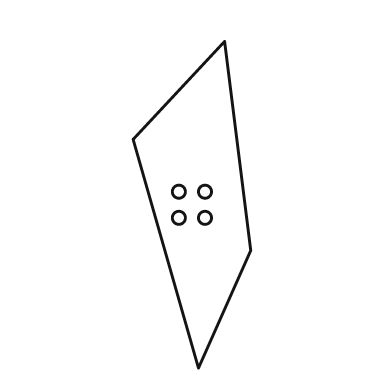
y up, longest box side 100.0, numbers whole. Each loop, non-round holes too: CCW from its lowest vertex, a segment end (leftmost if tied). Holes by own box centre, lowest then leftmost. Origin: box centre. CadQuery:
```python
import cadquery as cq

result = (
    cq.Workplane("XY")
    .moveTo(2.0, -50.0)
    .lineTo(18.0, -14.0)
    .lineTo(10.0, 50.0)
    .lineTo(-18.0, 20.0)
    .close()
    .moveTo(-4.0, -4.0)
    .circle(2.0)
    .moveTo(4.0, -4.0)
    .circle(2.0)
    .moveTo(-4.0, 4.0)
    .circle(2.0)
    .moveTo(4.0, 4.0)
    .circle(2.0)
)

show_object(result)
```